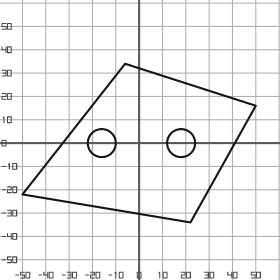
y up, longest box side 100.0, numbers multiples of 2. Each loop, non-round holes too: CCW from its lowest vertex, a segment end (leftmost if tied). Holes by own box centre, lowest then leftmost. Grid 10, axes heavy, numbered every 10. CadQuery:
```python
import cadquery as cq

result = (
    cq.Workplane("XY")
    .moveTo(22.0, -34.0)
    .lineTo(50.0, 16.0)
    .lineTo(-6.0, 34.0)
    .lineTo(-50.0, -22.0)
    .close()
    .moveTo(-16.0, 0.0)
    .circle(6.0)
    .moveTo(18.0, 0.0)
    .circle(6.0)
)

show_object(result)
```